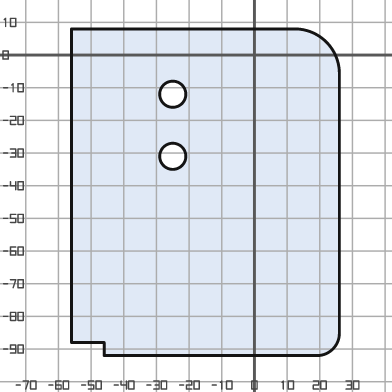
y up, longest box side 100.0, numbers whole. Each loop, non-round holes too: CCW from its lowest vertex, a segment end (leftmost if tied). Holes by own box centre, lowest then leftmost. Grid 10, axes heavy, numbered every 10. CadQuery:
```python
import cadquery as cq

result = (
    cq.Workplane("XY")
    .moveTo(-46.0, -92.0)
    .lineTo(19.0, -92.0)
    .threePointArc((24.0, -90.0), (26.0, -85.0))
    .lineTo(26.0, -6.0)
    .threePointArc((22.0, 4.0), (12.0, 8.0))
    .lineTo(-56.0, 8.0)
    .lineTo(-56.0, -88.0)
    .lineTo(-46.0, -88.0)
    .close()
    .moveTo(-25.0, -31.0)
    .circle(4.0)
    .moveTo(-25.0, -12.0)
    .circle(4.0)
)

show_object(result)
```